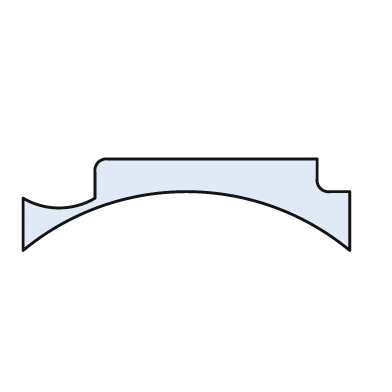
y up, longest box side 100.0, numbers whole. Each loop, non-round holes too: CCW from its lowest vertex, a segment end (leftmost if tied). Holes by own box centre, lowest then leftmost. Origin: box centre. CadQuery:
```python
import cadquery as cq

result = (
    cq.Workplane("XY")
    .moveTo(-50.0, -14.0)
    .threePointArc((0.0, 4.0), (50.0, -14.0))
    .lineTo(50.0, 4.0)
    .lineTo(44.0, 4.0)
    .threePointArc((41.0, 5.0), (40.0, 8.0))
    .lineTo(40.0, 14.0)
    .lineTo(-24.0, 14.0)
    .threePointArc((-27.0, 13.0), (-28.0, 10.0))
    .lineTo(-28.0, 2.0)
    .threePointArc((-39.0, -1.0), (-50.0, 2.0))
    .close()
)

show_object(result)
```